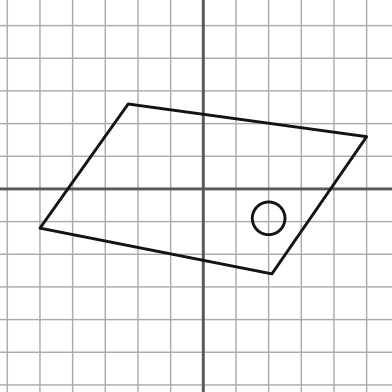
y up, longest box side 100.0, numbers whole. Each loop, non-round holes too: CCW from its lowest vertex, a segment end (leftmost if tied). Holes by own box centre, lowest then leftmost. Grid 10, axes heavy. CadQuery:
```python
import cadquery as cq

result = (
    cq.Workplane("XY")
    .moveTo(21.0, -26.0)
    .lineTo(50.0, 16.0)
    .lineTo(-23.0, 26.0)
    .lineTo(-50.0, -12.0)
    .close()
    .moveTo(20.0, -9.0)
    .circle(5.0)
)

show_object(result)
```